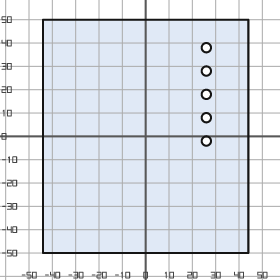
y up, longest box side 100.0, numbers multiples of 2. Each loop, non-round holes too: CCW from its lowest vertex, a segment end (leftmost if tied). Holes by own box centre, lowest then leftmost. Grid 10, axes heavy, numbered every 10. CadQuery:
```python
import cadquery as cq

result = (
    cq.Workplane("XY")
    .moveTo(-44.0, -50.0)
    .lineTo(44.0, -50.0)
    .lineTo(44.0, 50.0)
    .lineTo(-44.0, 50.0)
    .close()
    .moveTo(26.0, -2.0)
    .circle(2.0)
    .moveTo(26.0, 8.0)
    .circle(2.0)
    .moveTo(26.0, 18.0)
    .circle(2.0)
    .moveTo(26.0, 28.0)
    .circle(2.0)
    .moveTo(26.0, 38.0)
    .circle(2.0)
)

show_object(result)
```